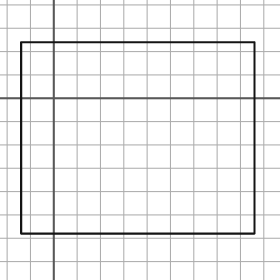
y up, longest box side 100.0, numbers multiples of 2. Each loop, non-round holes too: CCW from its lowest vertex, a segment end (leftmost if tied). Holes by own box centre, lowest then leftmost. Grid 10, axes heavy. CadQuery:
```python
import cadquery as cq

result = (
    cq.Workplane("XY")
    .moveTo(-14.0, -58.0)
    .lineTo(86.0, -58.0)
    .lineTo(86.0, 24.0)
    .lineTo(-14.0, 24.0)
    .close()
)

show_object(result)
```